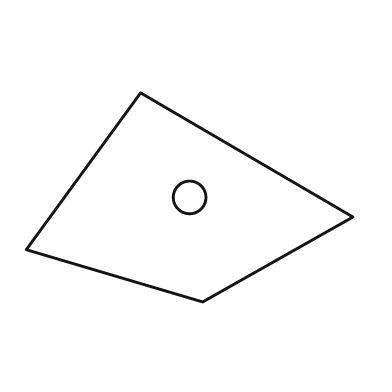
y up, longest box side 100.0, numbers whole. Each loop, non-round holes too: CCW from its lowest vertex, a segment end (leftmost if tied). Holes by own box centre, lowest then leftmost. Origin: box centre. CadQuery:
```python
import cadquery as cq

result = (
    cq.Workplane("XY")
    .moveTo(4.0, -32.0)
    .lineTo(50.0, -6.0)
    .lineTo(-15.0, 32.0)
    .lineTo(-50.0, -16.0)
    .close()
    .moveTo(0.0, 0.0)
    .circle(5.0)
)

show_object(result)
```